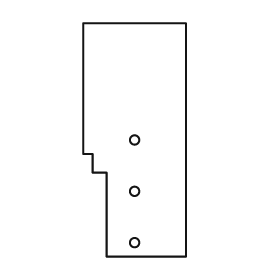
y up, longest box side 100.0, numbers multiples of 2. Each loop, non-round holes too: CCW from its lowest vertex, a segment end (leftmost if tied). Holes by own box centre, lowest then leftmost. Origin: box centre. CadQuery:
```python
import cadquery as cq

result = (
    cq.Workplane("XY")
    .moveTo(-12.0, -50.0)
    .lineTo(22.0, -50.0)
    .lineTo(22.0, 50.0)
    .lineTo(-22.0, 50.0)
    .lineTo(-22.0, -6.0)
    .lineTo(-18.0, -6.0)
    .lineTo(-18.0, -14.0)
    .lineTo(-12.0, -14.0)
    .close()
    .moveTo(0.0, -44.0)
    .circle(2.0)
    .moveTo(0.0, -22.0)
    .circle(2.0)
    .moveTo(0.0, 0.0)
    .circle(2.0)
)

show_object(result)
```